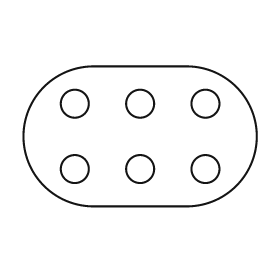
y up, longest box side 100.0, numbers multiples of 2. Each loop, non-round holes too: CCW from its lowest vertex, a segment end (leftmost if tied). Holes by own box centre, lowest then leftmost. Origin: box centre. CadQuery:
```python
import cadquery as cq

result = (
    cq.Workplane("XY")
    .moveTo(-20.0, -30.0)
    .lineTo(20.0, -30.0)
    .threePointArc((50.0, 0.0), (20.0, 30.0))
    .lineTo(-20.0, 30.0)
    .threePointArc((-50.0, 0.0), (-20.0, -30.0))
    .close()
    .moveTo(-28.0, -14.0)
    .circle(6.0)
    .moveTo(0.0, -14.0)
    .circle(6.0)
    .moveTo(28.0, -14.0)
    .circle(6.0)
    .moveTo(-28.0, 14.0)
    .circle(6.0)
    .moveTo(0.0, 14.0)
    .circle(6.0)
    .moveTo(28.0, 14.0)
    .circle(6.0)
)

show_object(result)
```